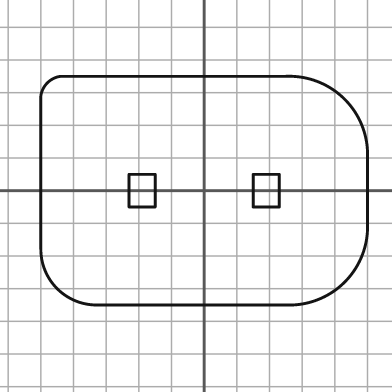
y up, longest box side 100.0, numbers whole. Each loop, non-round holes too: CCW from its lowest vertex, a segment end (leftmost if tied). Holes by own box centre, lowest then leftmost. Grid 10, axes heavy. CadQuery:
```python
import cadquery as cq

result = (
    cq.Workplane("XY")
    .moveTo(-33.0, -35.0)
    .lineTo(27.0, -35.0)
    .threePointArc((43.0, -28.0), (50.0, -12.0))
    .lineTo(50.0, 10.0)
    .threePointArc((43.0, 28.0), (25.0, 35.0))
    .lineTo(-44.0, 35.0)
    .threePointArc((-48.0, 33.0), (-50.0, 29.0))
    .lineTo(-50.0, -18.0)
    .threePointArc((-45.0, -30.0), (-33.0, -35.0))
    .close()
    .moveTo(-23.0, -5.0)
    .lineTo(-15.0, -5.0)
    .lineTo(-15.0, 5.0)
    .lineTo(-23.0, 5.0)
    .close()
    .moveTo(15.0, -5.0)
    .lineTo(23.0, -5.0)
    .lineTo(23.0, 5.0)
    .lineTo(15.0, 5.0)
    .close()
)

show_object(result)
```